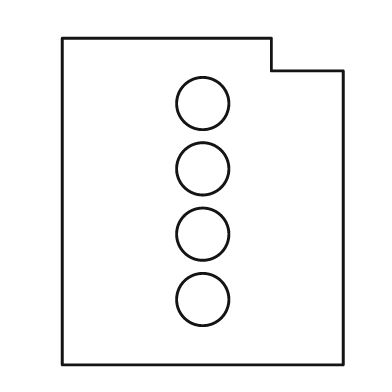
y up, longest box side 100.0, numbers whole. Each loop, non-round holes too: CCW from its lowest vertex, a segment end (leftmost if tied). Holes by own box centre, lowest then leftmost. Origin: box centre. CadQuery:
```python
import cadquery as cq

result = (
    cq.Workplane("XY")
    .moveTo(-43.0, -50.0)
    .lineTo(43.0, -50.0)
    .lineTo(43.0, 40.0)
    .lineTo(21.0, 40.0)
    .lineTo(21.0, 50.0)
    .lineTo(-43.0, 50.0)
    .close()
    .moveTo(0.0, -30.0)
    .circle(8.0)
    .moveTo(0.0, -10.0)
    .circle(8.0)
    .moveTo(0.0, 10.0)
    .circle(8.0)
    .moveTo(0.0, 30.0)
    .circle(8.0)
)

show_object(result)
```